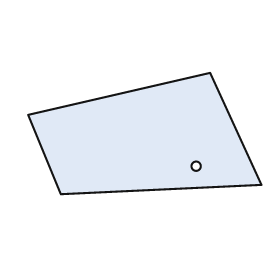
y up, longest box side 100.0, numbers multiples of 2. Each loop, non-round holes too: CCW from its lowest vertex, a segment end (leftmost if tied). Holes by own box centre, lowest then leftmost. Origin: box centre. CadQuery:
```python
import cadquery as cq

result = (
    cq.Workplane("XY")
    .moveTo(-36.0, -26.0)
    .lineTo(50.0, -22.0)
    .lineTo(28.0, 26.0)
    .lineTo(-50.0, 8.0)
    .close()
    .moveTo(22.0, -14.0)
    .circle(2.0)
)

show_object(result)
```